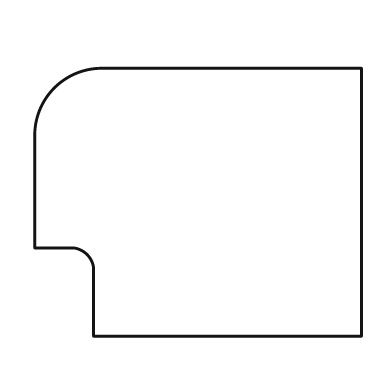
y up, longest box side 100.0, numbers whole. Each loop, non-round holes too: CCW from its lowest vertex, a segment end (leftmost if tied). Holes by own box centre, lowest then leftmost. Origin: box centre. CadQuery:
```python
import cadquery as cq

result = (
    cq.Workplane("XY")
    .moveTo(-32.0, -41.0)
    .lineTo(50.0, -41.0)
    .lineTo(50.0, 41.0)
    .lineTo(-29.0, 41.0)
    .threePointArc((-44.0, 35.0), (-50.0, 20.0))
    .lineTo(-50.0, -14.0)
    .lineTo(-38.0, -14.0)
    .threePointArc((-34.0, -16.0), (-32.0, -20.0))
    .close()
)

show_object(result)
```